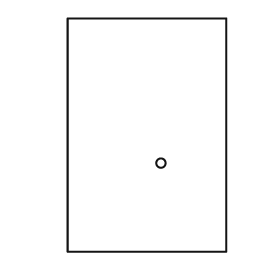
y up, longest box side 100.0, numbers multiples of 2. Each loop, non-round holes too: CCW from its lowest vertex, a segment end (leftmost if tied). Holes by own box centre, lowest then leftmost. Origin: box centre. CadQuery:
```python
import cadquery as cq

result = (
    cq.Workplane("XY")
    .moveTo(-34.0, -50.0)
    .lineTo(34.0, -50.0)
    .lineTo(34.0, 50.0)
    .lineTo(-34.0, 50.0)
    .close()
    .moveTo(6.0, -12.0)
    .circle(2.0)
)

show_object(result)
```